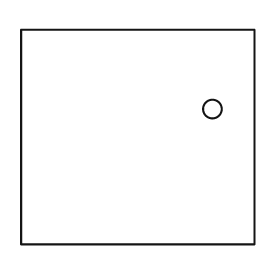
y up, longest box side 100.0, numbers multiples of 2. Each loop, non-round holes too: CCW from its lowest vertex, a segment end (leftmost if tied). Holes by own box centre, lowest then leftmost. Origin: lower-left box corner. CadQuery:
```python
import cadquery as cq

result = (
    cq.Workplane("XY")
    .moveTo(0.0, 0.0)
    .lineTo(100.0, 0.0)
    .lineTo(100.0, 92.0)
    .lineTo(0.0, 92.0)
    .close()
    .moveTo(82.0, 58.0)
    .circle(4.0)
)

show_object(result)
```